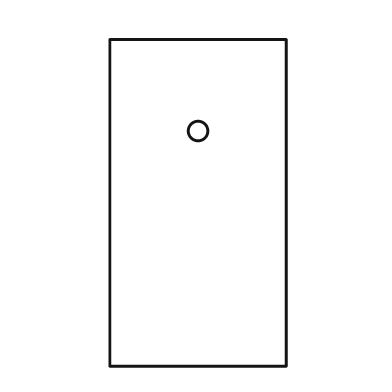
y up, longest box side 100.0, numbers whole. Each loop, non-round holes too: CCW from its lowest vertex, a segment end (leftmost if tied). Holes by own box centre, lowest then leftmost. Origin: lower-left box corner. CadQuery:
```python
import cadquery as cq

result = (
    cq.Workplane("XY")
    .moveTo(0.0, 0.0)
    .lineTo(54.0, 0.0)
    .lineTo(54.0, 100.0)
    .lineTo(0.0, 100.0)
    .close()
    .moveTo(27.0, 72.0)
    .circle(3.0)
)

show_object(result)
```